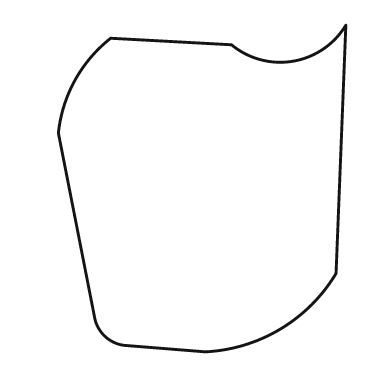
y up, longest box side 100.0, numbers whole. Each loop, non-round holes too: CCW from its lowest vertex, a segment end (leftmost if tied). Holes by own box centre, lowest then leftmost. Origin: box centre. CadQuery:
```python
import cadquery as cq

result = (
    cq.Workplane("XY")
    .moveTo(1.0, -50.0)
    .threePointArc((24.0, -43.0), (41.0, -26.0))
    .lineTo(44.0, 50.0)
    .threePointArc((28.0, 39.0), (9.0, 44.0))
    .lineTo(-28.0, 46.0)
    .threePointArc((-39.0, 33.0), (-44.0, 17.0))
    .lineTo(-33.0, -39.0)
    .threePointArc((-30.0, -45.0), (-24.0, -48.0))
    .close()
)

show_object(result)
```